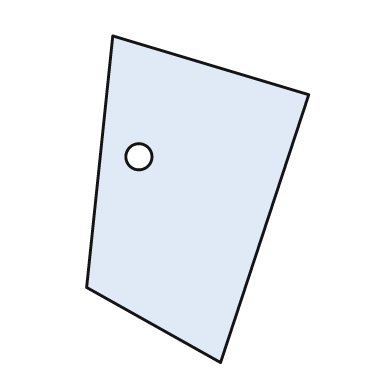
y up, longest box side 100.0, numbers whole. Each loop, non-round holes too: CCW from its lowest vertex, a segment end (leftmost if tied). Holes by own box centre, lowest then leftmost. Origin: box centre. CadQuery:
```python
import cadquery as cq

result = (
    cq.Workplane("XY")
    .moveTo(7.0, -50.0)
    .lineTo(34.0, 32.0)
    .lineTo(-26.0, 50.0)
    .lineTo(-34.0, -27.0)
    .close()
    .moveTo(-18.0, 13.0)
    .circle(4.0)
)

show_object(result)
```